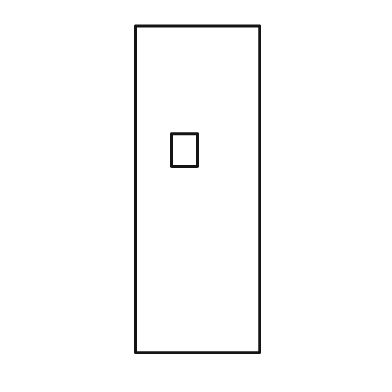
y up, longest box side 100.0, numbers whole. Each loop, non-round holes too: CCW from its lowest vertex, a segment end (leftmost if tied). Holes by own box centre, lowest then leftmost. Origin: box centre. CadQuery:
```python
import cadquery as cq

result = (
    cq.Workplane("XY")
    .moveTo(-19.0, -50.0)
    .lineTo(19.0, -50.0)
    .lineTo(19.0, 50.0)
    .lineTo(-19.0, 50.0)
    .close()
    .moveTo(-8.0, 7.0)
    .lineTo(0.0, 7.0)
    .lineTo(0.0, 17.0)
    .lineTo(-8.0, 17.0)
    .close()
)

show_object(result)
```